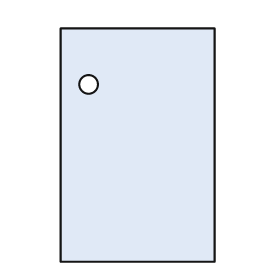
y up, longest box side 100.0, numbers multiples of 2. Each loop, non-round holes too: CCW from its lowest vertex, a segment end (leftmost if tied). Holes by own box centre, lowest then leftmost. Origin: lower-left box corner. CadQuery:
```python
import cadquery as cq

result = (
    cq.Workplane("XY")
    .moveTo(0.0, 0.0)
    .lineTo(66.0, 0.0)
    .lineTo(66.0, 100.0)
    .lineTo(0.0, 100.0)
    .close()
    .moveTo(12.0, 76.0)
    .circle(4.0)
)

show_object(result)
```